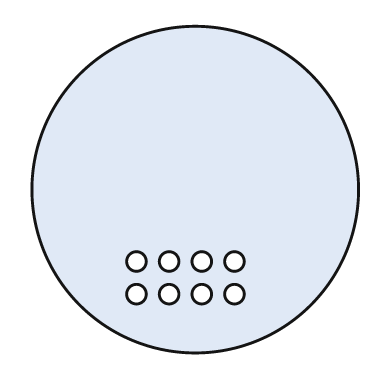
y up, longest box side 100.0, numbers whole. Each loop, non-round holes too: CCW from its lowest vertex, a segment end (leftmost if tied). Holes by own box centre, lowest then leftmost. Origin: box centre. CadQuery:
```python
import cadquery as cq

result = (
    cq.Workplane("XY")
    .moveTo(0.0, 0.0)
    .circle(50.0)
    .moveTo(-18.0, -32.0)
    .circle(3.0)
    .moveTo(-8.0, -32.0)
    .circle(3.0)
    .moveTo(2.0, -32.0)
    .circle(3.0)
    .moveTo(12.0, -32.0)
    .circle(3.0)
    .moveTo(-18.0, -22.0)
    .circle(3.0)
    .moveTo(-8.0, -22.0)
    .circle(3.0)
    .moveTo(2.0, -22.0)
    .circle(3.0)
    .moveTo(12.0, -22.0)
    .circle(3.0)
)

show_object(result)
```